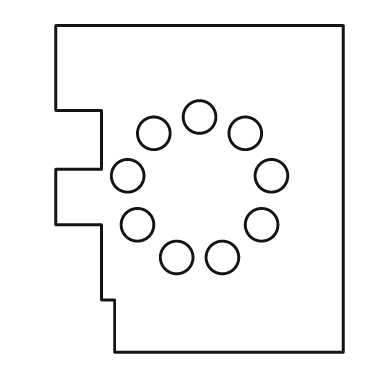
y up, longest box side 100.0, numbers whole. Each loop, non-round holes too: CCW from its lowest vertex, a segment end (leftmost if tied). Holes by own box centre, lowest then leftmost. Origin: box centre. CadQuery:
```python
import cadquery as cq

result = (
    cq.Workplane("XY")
    .moveTo(-26.0, -50.0)
    .lineTo(44.0, -50.0)
    .lineTo(44.0, 50.0)
    .lineTo(-44.0, 50.0)
    .lineTo(-44.0, 24.0)
    .lineTo(-30.0, 24.0)
    .lineTo(-30.0, 6.0)
    .lineTo(-44.0, 6.0)
    .lineTo(-44.0, -11.0)
    .lineTo(-30.0, -11.0)
    .lineTo(-30.0, -34.0)
    .lineTo(-26.0, -34.0)
    .close()
    .moveTo(-7.0, -21.0)
    .circle(5.0)
    .moveTo(7.0, -21.0)
    .circle(5.0)
    .moveTo(-19.0, -11.0)
    .circle(5.0)
    .moveTo(19.0, -11.0)
    .circle(5.0)
    .moveTo(-22.0, 4.0)
    .circle(5.0)
    .moveTo(22.0, 4.0)
    .circle(5.0)
    .moveTo(-14.0, 17.0)
    .circle(5.0)
    .moveTo(14.0, 17.0)
    .circle(5.0)
    .moveTo(0.0, 22.0)
    .circle(5.0)
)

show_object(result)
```